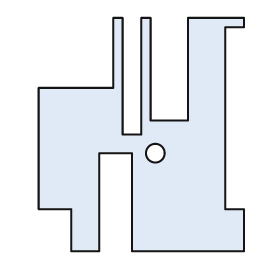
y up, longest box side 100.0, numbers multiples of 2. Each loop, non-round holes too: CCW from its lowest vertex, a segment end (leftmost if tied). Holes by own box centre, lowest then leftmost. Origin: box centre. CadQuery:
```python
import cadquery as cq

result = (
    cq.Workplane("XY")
    .moveTo(-30.0, -50.0)
    .lineTo(-18.0, -50.0)
    .lineTo(-18.0, -8.0)
    .lineTo(-4.0, -8.0)
    .lineTo(-4.0, -50.0)
    .lineTo(44.0, -50.0)
    .lineTo(44.0, -32.0)
    .lineTo(36.0, -32.0)
    .lineTo(36.0, 46.0)
    .lineTo(44.0, 46.0)
    .lineTo(44.0, 50.0)
    .lineTo(20.0, 50.0)
    .lineTo(20.0, 6.0)
    .lineTo(4.0, 6.0)
    .lineTo(4.0, 50.0)
    .lineTo(0.0, 50.0)
    .lineTo(0.0, 0.0)
    .lineTo(-8.0, 0.0)
    .lineTo(-8.0, 50.0)
    .lineTo(-12.0, 50.0)
    .lineTo(-12.0, 20.0)
    .lineTo(-44.0, 20.0)
    .lineTo(-44.0, -32.0)
    .lineTo(-30.0, -32.0)
    .close()
    .moveTo(6.0, -8.0)
    .circle(4.0)
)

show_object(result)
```